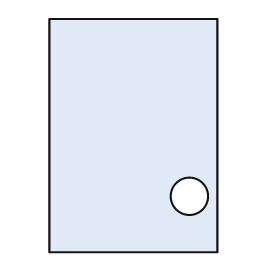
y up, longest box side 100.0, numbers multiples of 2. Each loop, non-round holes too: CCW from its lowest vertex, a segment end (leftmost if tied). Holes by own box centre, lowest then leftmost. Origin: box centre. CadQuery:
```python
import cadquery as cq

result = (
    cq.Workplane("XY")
    .moveTo(-36.0, -50.0)
    .lineTo(36.0, -50.0)
    .lineTo(36.0, 50.0)
    .lineTo(-36.0, 50.0)
    .close()
    .moveTo(24.0, -26.0)
    .circle(8.0)
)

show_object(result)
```